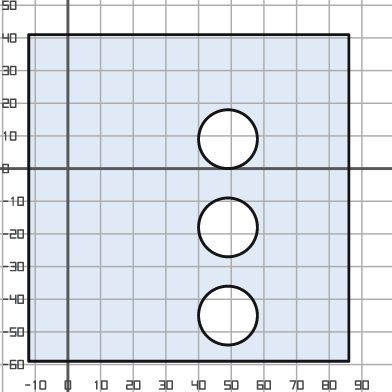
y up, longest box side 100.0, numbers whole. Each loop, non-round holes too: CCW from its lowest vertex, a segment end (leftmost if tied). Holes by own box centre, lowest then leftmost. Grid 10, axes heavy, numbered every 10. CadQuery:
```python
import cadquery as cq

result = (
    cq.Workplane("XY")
    .moveTo(-12.0, -59.0)
    .lineTo(86.0, -59.0)
    .lineTo(86.0, 41.0)
    .lineTo(-12.0, 41.0)
    .close()
    .moveTo(49.0, -45.0)
    .circle(9.0)
    .moveTo(49.0, -18.0)
    .circle(9.0)
    .moveTo(49.0, 9.0)
    .circle(9.0)
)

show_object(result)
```